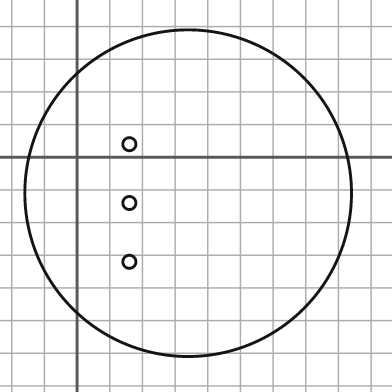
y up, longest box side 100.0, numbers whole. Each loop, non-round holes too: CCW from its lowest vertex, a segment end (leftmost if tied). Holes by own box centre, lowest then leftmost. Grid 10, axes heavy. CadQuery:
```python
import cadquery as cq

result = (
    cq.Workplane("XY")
    .moveTo(34.0, -11.0)
    .circle(50.0)
    .moveTo(16.0, -32.0)
    .circle(2.0)
    .moveTo(16.0, -14.0)
    .circle(2.0)
    .moveTo(16.0, 4.0)
    .circle(2.0)
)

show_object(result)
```